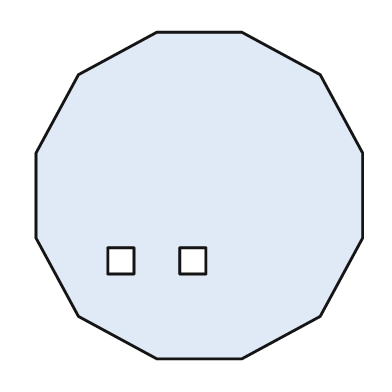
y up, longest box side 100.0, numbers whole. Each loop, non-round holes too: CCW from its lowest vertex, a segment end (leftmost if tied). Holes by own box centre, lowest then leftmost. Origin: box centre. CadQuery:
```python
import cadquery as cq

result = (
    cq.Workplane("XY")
    .moveTo(-13.0, -50.0)
    .lineTo(13.0, -50.0)
    .lineTo(37.0, -37.0)
    .lineTo(50.0, -13.0)
    .lineTo(50.0, 13.0)
    .lineTo(37.0, 37.0)
    .lineTo(13.0, 50.0)
    .lineTo(-13.0, 50.0)
    .lineTo(-37.0, 37.0)
    .lineTo(-50.0, 13.0)
    .lineTo(-50.0, -13.0)
    .lineTo(-37.0, -37.0)
    .close()
    .moveTo(-28.0, -24.0)
    .lineTo(-20.0, -24.0)
    .lineTo(-20.0, -16.0)
    .lineTo(-28.0, -16.0)
    .close()
    .moveTo(-6.0, -24.0)
    .lineTo(2.0, -24.0)
    .lineTo(2.0, -16.0)
    .lineTo(-6.0, -16.0)
    .close()
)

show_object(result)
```